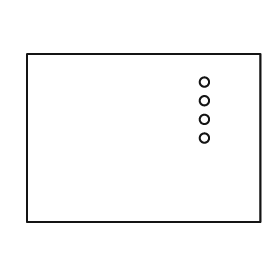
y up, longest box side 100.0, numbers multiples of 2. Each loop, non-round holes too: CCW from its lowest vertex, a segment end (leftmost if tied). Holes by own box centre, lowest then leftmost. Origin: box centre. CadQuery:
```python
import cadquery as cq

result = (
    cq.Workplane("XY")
    .moveTo(-50.0, -36.0)
    .lineTo(50.0, -36.0)
    .lineTo(50.0, 36.0)
    .lineTo(-50.0, 36.0)
    .close()
    .moveTo(26.0, 0.0)
    .circle(2.0)
    .moveTo(26.0, 8.0)
    .circle(2.0)
    .moveTo(26.0, 16.0)
    .circle(2.0)
    .moveTo(26.0, 24.0)
    .circle(2.0)
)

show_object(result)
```